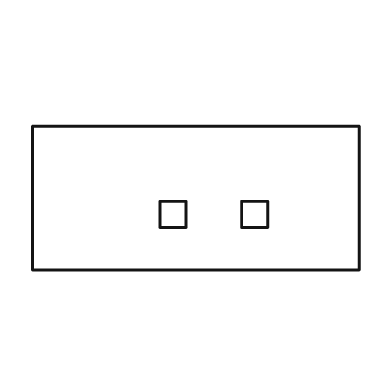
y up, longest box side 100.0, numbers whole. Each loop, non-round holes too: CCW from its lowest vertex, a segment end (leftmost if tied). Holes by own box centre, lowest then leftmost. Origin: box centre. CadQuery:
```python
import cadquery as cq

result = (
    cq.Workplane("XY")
    .moveTo(-50.0, -22.0)
    .lineTo(50.0, -22.0)
    .lineTo(50.0, 22.0)
    .lineTo(-50.0, 22.0)
    .close()
    .moveTo(-11.0, -9.0)
    .lineTo(-3.0, -9.0)
    .lineTo(-3.0, -1.0)
    .lineTo(-11.0, -1.0)
    .close()
    .moveTo(14.0, -9.0)
    .lineTo(22.0, -9.0)
    .lineTo(22.0, -1.0)
    .lineTo(14.0, -1.0)
    .close()
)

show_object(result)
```